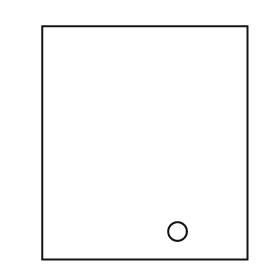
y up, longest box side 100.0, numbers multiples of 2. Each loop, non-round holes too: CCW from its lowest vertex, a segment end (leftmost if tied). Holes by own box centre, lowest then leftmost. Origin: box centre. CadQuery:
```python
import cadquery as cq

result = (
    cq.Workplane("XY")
    .moveTo(-44.0, -50.0)
    .lineTo(44.0, -50.0)
    .lineTo(44.0, 50.0)
    .lineTo(-44.0, 50.0)
    .close()
    .moveTo(14.0, -38.0)
    .circle(4.0)
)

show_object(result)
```